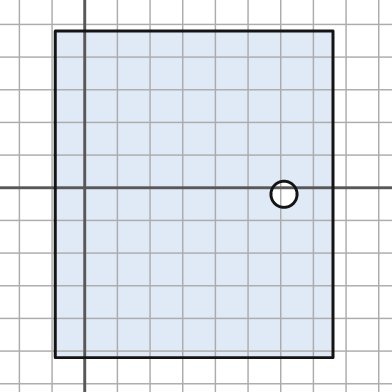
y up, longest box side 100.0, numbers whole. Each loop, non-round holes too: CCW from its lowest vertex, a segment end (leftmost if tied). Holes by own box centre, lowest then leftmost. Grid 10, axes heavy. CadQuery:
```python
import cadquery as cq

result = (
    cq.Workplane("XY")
    .moveTo(-9.0, -52.0)
    .lineTo(76.0, -52.0)
    .lineTo(76.0, 48.0)
    .lineTo(-9.0, 48.0)
    .close()
    .moveTo(61.0, -2.0)
    .circle(4.0)
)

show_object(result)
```